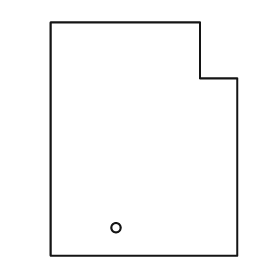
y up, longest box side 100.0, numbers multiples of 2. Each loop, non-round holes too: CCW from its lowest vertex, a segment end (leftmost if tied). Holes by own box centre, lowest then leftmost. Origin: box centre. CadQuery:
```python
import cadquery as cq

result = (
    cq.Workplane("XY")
    .moveTo(-40.0, -50.0)
    .lineTo(40.0, -50.0)
    .lineTo(40.0, 26.0)
    .lineTo(24.0, 26.0)
    .lineTo(24.0, 50.0)
    .lineTo(-40.0, 50.0)
    .close()
    .moveTo(-12.0, -38.0)
    .circle(2.0)
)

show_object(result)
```